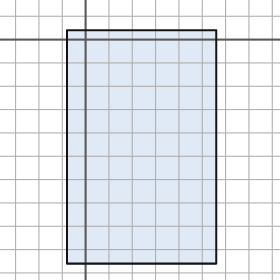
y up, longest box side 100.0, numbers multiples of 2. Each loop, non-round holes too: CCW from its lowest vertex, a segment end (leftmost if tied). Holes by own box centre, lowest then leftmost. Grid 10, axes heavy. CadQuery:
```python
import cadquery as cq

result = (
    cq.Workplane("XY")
    .moveTo(-8.0, -96.0)
    .lineTo(56.0, -96.0)
    .lineTo(56.0, 4.0)
    .lineTo(-8.0, 4.0)
    .close()
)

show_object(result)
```